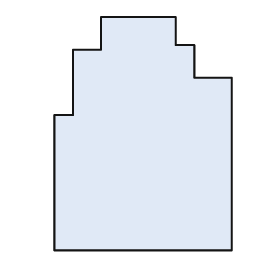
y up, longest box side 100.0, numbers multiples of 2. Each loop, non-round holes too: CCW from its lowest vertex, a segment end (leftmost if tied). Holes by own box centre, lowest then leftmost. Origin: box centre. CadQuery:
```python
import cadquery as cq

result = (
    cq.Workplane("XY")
    .moveTo(-38.0, -50.0)
    .lineTo(38.0, -50.0)
    .lineTo(38.0, 24.0)
    .lineTo(22.0, 24.0)
    .lineTo(22.0, 38.0)
    .lineTo(14.0, 38.0)
    .lineTo(14.0, 50.0)
    .lineTo(-18.0, 50.0)
    .lineTo(-18.0, 36.0)
    .lineTo(-30.0, 36.0)
    .lineTo(-30.0, 8.0)
    .lineTo(-38.0, 8.0)
    .close()
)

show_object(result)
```